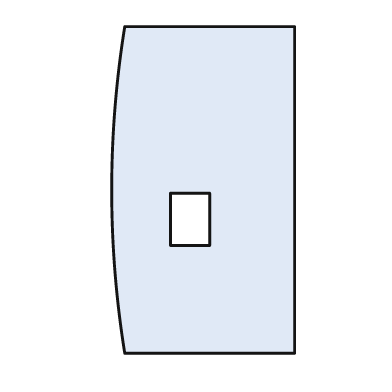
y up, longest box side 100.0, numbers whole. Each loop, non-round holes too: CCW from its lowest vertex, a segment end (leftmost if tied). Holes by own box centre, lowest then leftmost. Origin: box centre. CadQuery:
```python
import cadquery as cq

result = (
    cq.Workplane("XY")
    .moveTo(-24.0, -50.0)
    .lineTo(28.0, -50.0)
    .lineTo(28.0, 50.0)
    .lineTo(-24.0, 50.0)
    .threePointArc((-28.0, 0.0), (-24.0, -50.0))
    .close()
    .moveTo(-10.0, -17.0)
    .lineTo(2.0, -17.0)
    .lineTo(2.0, -1.0)
    .lineTo(-10.0, -1.0)
    .close()
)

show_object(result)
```